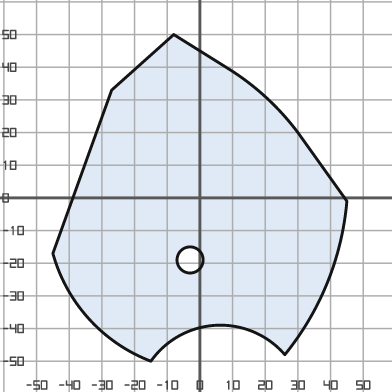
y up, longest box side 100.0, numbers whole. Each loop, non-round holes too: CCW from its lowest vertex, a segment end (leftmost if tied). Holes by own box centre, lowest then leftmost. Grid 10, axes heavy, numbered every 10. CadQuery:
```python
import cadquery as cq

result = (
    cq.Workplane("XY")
    .moveTo(-15.0, -50.0)
    .threePointArc((5.0, -39.0), (26.0, -48.0))
    .threePointArc((39.0, -26.0), (45.0, -1.0))
    .lineTo(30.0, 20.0)
    .threePointArc((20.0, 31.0), (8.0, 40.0))
    .lineTo(-8.0, 50.0)
    .lineTo(-27.0, 33.0)
    .lineTo(-45.0, -17.0)
    .threePointArc((-34.0, -37.0), (-15.0, -50.0))
    .close()
    .moveTo(-3.0, -19.0)
    .circle(4.0)
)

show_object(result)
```